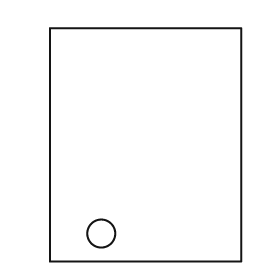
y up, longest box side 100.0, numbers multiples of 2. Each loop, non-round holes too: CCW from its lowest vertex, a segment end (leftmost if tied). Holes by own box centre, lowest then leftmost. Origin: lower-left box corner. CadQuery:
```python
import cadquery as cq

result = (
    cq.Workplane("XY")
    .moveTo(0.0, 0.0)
    .lineTo(82.0, 0.0)
    .lineTo(82.0, 100.0)
    .lineTo(0.0, 100.0)
    .close()
    .moveTo(22.0, 12.0)
    .circle(6.0)
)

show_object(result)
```